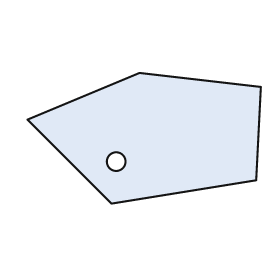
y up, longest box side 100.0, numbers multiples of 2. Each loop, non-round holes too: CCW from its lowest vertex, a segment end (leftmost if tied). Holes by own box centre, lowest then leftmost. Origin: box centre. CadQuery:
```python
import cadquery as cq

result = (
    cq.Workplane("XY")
    .moveTo(-14.0, -28.0)
    .lineTo(48.0, -18.0)
    .lineTo(50.0, 22.0)
    .lineTo(-2.0, 28.0)
    .lineTo(-50.0, 8.0)
    .close()
    .moveTo(-12.0, -10.0)
    .circle(4.0)
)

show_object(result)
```